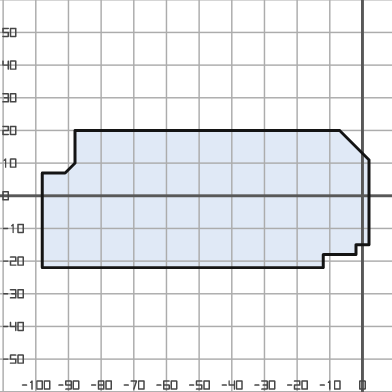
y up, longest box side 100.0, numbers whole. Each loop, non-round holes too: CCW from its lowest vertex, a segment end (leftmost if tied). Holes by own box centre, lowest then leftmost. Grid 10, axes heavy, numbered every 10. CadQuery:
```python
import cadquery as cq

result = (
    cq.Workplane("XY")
    .moveTo(-98.0, -22.0)
    .lineTo(-12.0, -22.0)
    .lineTo(-12.0, -18.0)
    .lineTo(-2.0, -18.0)
    .lineTo(-2.0, -15.0)
    .lineTo(2.0, -15.0)
    .lineTo(2.0, 11.0)
    .lineTo(-7.0, 20.0)
    .lineTo(-88.0, 20.0)
    .lineTo(-88.0, 10.0)
    .lineTo(-91.0, 7.0)
    .lineTo(-98.0, 7.0)
    .close()
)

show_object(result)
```